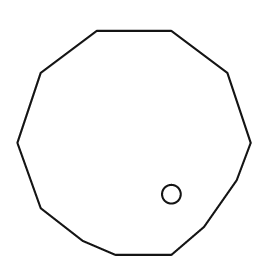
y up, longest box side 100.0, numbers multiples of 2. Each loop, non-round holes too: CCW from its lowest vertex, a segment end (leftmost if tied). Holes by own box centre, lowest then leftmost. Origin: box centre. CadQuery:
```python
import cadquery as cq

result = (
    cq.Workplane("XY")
    .moveTo(-8.0, -48.0)
    .lineTo(16.0, -48.0)
    .lineTo(30.0, -36.0)
    .lineTo(44.0, -16.0)
    .lineTo(50.0, 0.0)
    .lineTo(40.0, 30.0)
    .lineTo(16.0, 48.0)
    .lineTo(-16.0, 48.0)
    .lineTo(-40.0, 30.0)
    .lineTo(-50.0, 0.0)
    .lineTo(-40.0, -28.0)
    .lineTo(-22.0, -42.0)
    .close()
    .moveTo(16.0, -22.0)
    .circle(4.0)
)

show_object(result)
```